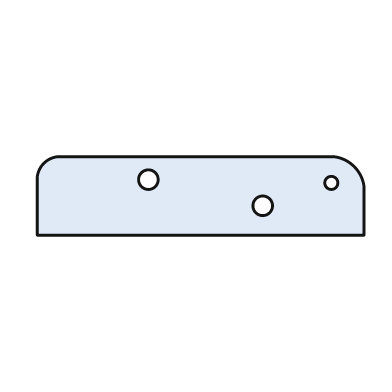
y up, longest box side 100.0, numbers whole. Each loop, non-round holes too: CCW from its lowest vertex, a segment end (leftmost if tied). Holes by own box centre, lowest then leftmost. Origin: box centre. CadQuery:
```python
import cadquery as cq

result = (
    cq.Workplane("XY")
    .moveTo(-50.0, -12.0)
    .lineTo(50.0, -12.0)
    .lineTo(50.0, 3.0)
    .threePointArc((47.0, 9.0), (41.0, 12.0))
    .lineTo(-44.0, 12.0)
    .threePointArc((-48.0, 10.0), (-50.0, 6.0))
    .close()
    .moveTo(19.0, -3.0)
    .circle(3.0)
    .moveTo(40.0, 4.0)
    .circle(2.0)
    .moveTo(-16.0, 5.0)
    .circle(3.0)
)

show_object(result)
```